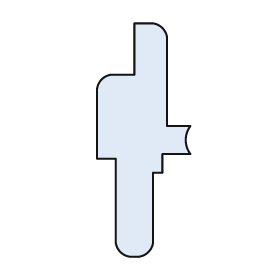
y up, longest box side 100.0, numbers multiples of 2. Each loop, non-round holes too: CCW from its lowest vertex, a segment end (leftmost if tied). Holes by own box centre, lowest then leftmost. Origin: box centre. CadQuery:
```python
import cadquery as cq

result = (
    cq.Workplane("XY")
    .moveTo(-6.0, -50.0)
    .lineTo(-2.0, -50.0)
    .threePointArc((2.0, -48.0), (4.0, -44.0))
    .lineTo(4.0, -14.0)
    .lineTo(8.0, -14.0)
    .lineTo(8.0, -6.0)
    .lineTo(20.0, -6.0)
    .threePointArc((18.0, 0.0), (20.0, 6.0))
    .lineTo(10.0, 6.0)
    .lineTo(10.0, 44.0)
    .threePointArc((8.0, 48.0), (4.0, 50.0))
    .lineTo(-4.0, 50.0)
    .lineTo(-4.0, 28.0)
    .lineTo(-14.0, 28.0)
    .threePointArc((-18.0, 26.0), (-20.0, 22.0))
    .lineTo(-20.0, -8.0)
    .lineTo(-12.0, -8.0)
    .lineTo(-12.0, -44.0)
    .threePointArc((-10.0, -48.0), (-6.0, -50.0))
    .close()
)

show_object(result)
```